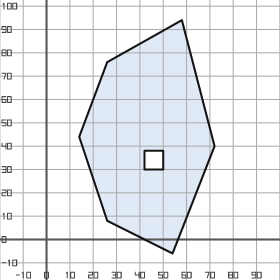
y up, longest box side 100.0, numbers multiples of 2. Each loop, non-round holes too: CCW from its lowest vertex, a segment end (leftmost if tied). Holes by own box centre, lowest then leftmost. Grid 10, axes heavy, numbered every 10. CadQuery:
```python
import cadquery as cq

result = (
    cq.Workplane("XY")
    .moveTo(54.0, -6.0)
    .lineTo(72.0, 40.0)
    .lineTo(58.0, 94.0)
    .lineTo(26.0, 76.0)
    .lineTo(14.0, 44.0)
    .lineTo(26.0, 8.0)
    .close()
    .moveTo(42.0, 30.0)
    .lineTo(50.0, 30.0)
    .lineTo(50.0, 38.0)
    .lineTo(42.0, 38.0)
    .close()
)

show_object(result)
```